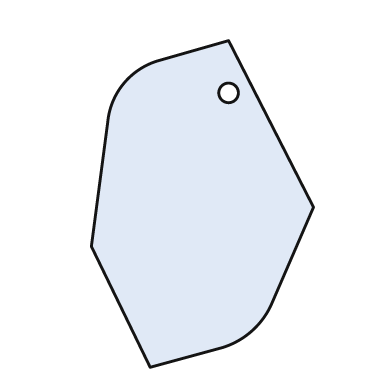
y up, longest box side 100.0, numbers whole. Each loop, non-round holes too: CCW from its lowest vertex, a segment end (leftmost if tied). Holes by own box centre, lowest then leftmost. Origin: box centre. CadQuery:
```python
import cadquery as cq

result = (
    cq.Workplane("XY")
    .moveTo(-16.0, -50.0)
    .lineTo(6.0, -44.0)
    .threePointArc((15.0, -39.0), (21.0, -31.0))
    .lineTo(34.0, -1.0)
    .lineTo(8.0, 50.0)
    .lineTo(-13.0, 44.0)
    .threePointArc((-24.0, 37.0), (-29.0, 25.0))
    .lineTo(-34.0, -13.0)
    .close()
    .moveTo(8.0, 34.0)
    .circle(3.0)
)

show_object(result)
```